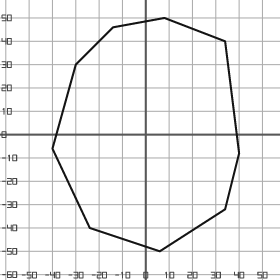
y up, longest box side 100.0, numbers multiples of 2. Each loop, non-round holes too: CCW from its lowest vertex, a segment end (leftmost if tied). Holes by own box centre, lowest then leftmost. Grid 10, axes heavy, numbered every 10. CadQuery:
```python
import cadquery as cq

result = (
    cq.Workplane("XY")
    .moveTo(6.0, -50.0)
    .lineTo(34.0, -32.0)
    .lineTo(40.0, -8.0)
    .lineTo(34.0, 40.0)
    .lineTo(8.0, 50.0)
    .lineTo(-14.0, 46.0)
    .lineTo(-30.0, 30.0)
    .lineTo(-40.0, -6.0)
    .lineTo(-24.0, -40.0)
    .close()
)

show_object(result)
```